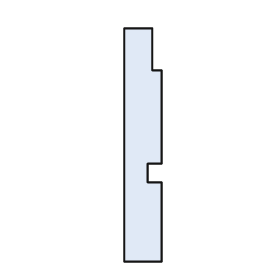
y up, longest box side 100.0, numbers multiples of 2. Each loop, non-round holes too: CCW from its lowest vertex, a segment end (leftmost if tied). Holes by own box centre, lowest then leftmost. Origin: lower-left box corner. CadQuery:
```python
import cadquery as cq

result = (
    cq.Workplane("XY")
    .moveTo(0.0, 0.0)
    .lineTo(16.0, 0.0)
    .lineTo(16.0, 34.0)
    .lineTo(10.0, 34.0)
    .lineTo(10.0, 42.0)
    .lineTo(16.0, 42.0)
    .lineTo(16.0, 82.0)
    .lineTo(12.0, 82.0)
    .lineTo(12.0, 100.0)
    .lineTo(0.0, 100.0)
    .close()
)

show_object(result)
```